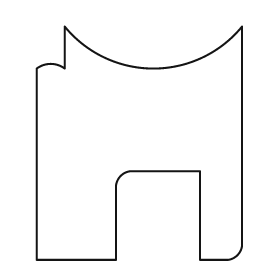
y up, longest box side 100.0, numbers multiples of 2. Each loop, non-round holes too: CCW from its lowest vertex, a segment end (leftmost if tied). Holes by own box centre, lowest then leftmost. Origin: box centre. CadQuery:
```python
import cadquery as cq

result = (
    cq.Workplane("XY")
    .moveTo(-44.0, -50.0)
    .lineTo(-10.0, -50.0)
    .lineTo(-10.0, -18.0)
    .threePointArc((-8.0, -14.0), (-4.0, -12.0))
    .lineTo(26.0, -12.0)
    .lineTo(26.0, -50.0)
    .lineTo(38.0, -50.0)
    .threePointArc((42.0, -48.0), (44.0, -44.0))
    .lineTo(44.0, 50.0)
    .threePointArc((6.0, 32.0), (-32.0, 50.0))
    .lineTo(-32.0, 32.0)
    .threePointArc((-38.0, 34.0), (-44.0, 32.0))
    .close()
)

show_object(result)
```